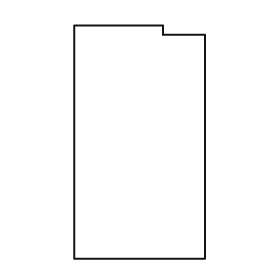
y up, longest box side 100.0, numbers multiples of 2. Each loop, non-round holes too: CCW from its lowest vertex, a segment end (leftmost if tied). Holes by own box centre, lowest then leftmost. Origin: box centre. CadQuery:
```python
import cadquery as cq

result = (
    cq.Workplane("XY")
    .moveTo(-28.0, -50.0)
    .lineTo(28.0, -50.0)
    .lineTo(28.0, 46.0)
    .lineTo(10.0, 46.0)
    .lineTo(10.0, 50.0)
    .lineTo(-28.0, 50.0)
    .close()
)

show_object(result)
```